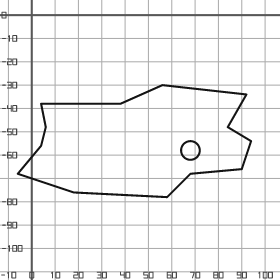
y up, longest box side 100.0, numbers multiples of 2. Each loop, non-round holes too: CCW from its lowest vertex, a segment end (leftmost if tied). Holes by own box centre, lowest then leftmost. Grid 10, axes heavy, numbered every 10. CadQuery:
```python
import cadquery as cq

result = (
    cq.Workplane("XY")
    .moveTo(58.0, -78.0)
    .lineTo(68.0, -68.0)
    .lineTo(90.0, -66.0)
    .lineTo(94.0, -54.0)
    .lineTo(84.0, -48.0)
    .lineTo(92.0, -34.0)
    .lineTo(56.0, -30.0)
    .lineTo(38.0, -38.0)
    .lineTo(4.0, -38.0)
    .lineTo(6.0, -48.0)
    .lineTo(4.0, -56.0)
    .lineTo(-6.0, -68.0)
    .lineTo(18.0, -76.0)
    .close()
    .moveTo(68.0, -58.0)
    .circle(4.0)
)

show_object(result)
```